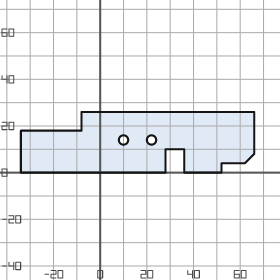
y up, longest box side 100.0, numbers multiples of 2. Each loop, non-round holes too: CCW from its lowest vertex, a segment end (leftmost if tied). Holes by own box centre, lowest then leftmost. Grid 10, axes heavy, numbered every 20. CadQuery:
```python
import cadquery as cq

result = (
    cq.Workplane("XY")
    .moveTo(-34.0, 0.0)
    .lineTo(28.0, 0.0)
    .lineTo(28.0, 10.0)
    .lineTo(36.0, 10.0)
    .lineTo(36.0, 0.0)
    .lineTo(52.0, 0.0)
    .lineTo(52.0, 4.0)
    .lineTo(62.0, 4.0)
    .lineTo(66.0, 8.0)
    .lineTo(66.0, 26.0)
    .lineTo(-8.0, 26.0)
    .lineTo(-8.0, 18.0)
    .lineTo(-34.0, 18.0)
    .close()
    .moveTo(10.0, 14.0)
    .circle(2.0)
    .moveTo(22.0, 14.0)
    .circle(2.0)
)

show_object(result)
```